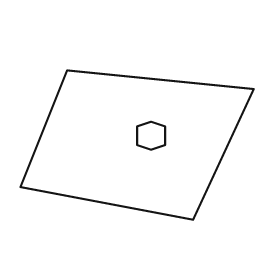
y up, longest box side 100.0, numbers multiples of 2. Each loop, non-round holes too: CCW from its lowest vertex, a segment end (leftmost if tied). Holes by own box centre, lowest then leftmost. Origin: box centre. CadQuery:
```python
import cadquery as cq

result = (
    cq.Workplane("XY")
    .moveTo(24.0, -32.0)
    .lineTo(50.0, 24.0)
    .lineTo(-30.0, 32.0)
    .lineTo(-50.0, -18.0)
    .close()
    .moveTo(6.0, -2.0)
    .lineTo(12.0, 0.0)
    .lineTo(12.0, 8.0)
    .lineTo(6.0, 10.0)
    .lineTo(0.0, 8.0)
    .lineTo(0.0, 0.0)
    .close()
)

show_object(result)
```